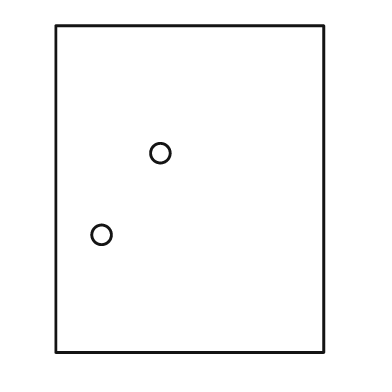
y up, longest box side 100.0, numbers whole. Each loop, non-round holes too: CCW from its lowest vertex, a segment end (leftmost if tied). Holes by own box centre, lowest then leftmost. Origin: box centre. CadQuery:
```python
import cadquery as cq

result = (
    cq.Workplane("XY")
    .moveTo(-41.0, -50.0)
    .lineTo(41.0, -50.0)
    .lineTo(41.0, 50.0)
    .lineTo(-41.0, 50.0)
    .close()
    .moveTo(-27.0, -14.0)
    .circle(3.0)
    .moveTo(-9.0, 11.0)
    .circle(3.0)
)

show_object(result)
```